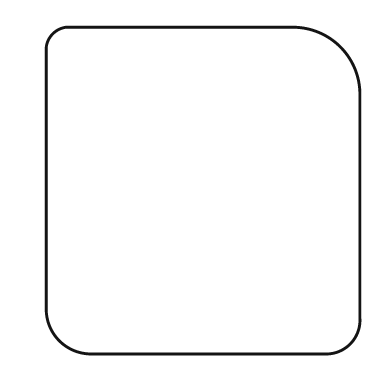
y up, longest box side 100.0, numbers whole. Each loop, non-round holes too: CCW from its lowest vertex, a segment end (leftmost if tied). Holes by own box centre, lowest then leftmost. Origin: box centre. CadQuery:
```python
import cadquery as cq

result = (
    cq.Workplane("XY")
    .moveTo(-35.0, -50.0)
    .lineTo(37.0, -50.0)
    .threePointArc((45.0, -47.0), (48.0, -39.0))
    .lineTo(48.0, 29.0)
    .threePointArc((42.0, 44.0), (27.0, 50.0))
    .lineTo(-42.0, 50.0)
    .threePointArc((-46.0, 48.0), (-48.0, 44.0))
    .lineTo(-48.0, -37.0)
    .threePointArc((-44.0, -46.0), (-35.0, -50.0))
    .close()
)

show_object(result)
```